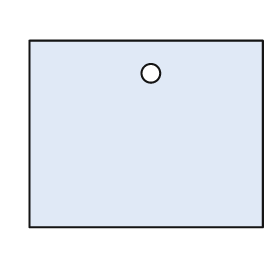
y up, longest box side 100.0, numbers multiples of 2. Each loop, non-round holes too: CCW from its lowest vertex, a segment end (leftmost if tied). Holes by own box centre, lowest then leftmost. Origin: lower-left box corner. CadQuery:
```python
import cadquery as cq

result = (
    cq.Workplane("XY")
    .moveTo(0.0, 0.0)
    .lineTo(100.0, 0.0)
    .lineTo(100.0, 80.0)
    .lineTo(0.0, 80.0)
    .close()
    .moveTo(52.0, 66.0)
    .circle(4.0)
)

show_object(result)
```